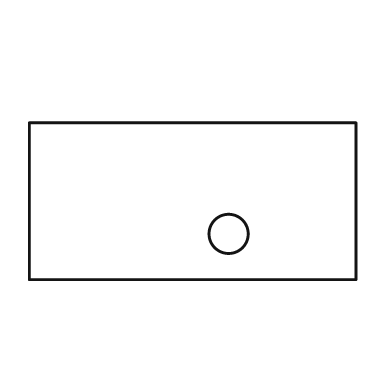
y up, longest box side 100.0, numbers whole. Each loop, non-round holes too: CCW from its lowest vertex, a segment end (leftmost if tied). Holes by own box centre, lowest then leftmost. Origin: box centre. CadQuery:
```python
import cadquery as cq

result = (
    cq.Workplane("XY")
    .moveTo(-50.0, -24.0)
    .lineTo(50.0, -24.0)
    .lineTo(50.0, 24.0)
    .lineTo(-50.0, 24.0)
    .close()
    .moveTo(11.0, -10.0)
    .circle(6.0)
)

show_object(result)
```